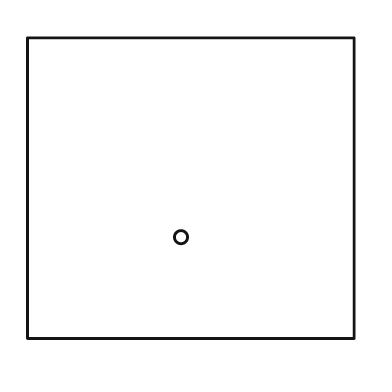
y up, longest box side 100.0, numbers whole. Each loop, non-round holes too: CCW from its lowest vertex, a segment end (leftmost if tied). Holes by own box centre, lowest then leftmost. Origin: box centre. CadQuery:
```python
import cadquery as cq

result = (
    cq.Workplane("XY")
    .moveTo(-50.0, -46.0)
    .lineTo(50.0, -46.0)
    .lineTo(50.0, 46.0)
    .lineTo(-50.0, 46.0)
    .close()
    .moveTo(-3.0, -15.0)
    .circle(2.0)
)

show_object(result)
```